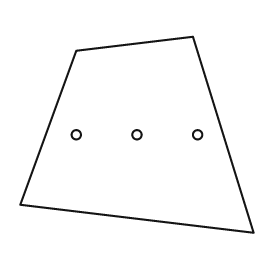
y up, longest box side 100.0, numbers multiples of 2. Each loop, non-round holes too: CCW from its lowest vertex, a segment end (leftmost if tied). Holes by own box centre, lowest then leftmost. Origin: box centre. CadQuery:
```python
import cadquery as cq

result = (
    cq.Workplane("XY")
    .moveTo(50.0, -42.0)
    .lineTo(24.0, 42.0)
    .lineTo(-26.0, 36.0)
    .lineTo(-50.0, -30.0)
    .close()
    .moveTo(-26.0, 0.0)
    .circle(2.0)
    .moveTo(0.0, 0.0)
    .circle(2.0)
    .moveTo(26.0, 0.0)
    .circle(2.0)
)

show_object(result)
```